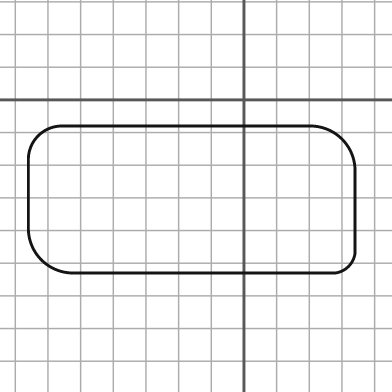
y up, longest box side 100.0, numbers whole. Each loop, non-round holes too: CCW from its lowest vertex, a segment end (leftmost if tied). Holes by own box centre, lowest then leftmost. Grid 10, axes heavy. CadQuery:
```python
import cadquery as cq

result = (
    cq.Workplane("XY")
    .moveTo(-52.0, -53.0)
    .lineTo(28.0, -53.0)
    .threePointArc((32.0, -51.0), (34.0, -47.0))
    .lineTo(34.0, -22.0)
    .threePointArc((30.0, -12.0), (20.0, -8.0))
    .lineTo(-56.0, -8.0)
    .threePointArc((-63.0, -11.0), (-66.0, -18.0))
    .lineTo(-66.0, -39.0)
    .threePointArc((-62.0, -49.0), (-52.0, -53.0))
    .close()
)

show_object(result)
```